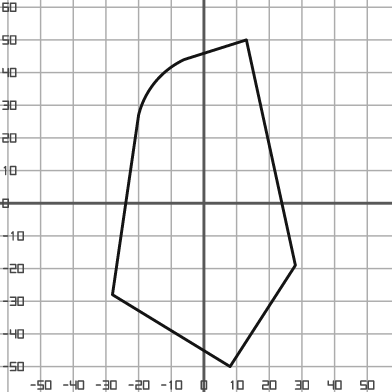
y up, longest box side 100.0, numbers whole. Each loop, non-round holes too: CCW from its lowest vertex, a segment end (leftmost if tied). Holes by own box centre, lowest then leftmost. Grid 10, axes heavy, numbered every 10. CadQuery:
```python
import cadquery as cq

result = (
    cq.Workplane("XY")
    .moveTo(8.0, -50.0)
    .lineTo(28.0, -19.0)
    .lineTo(13.0, 50.0)
    .lineTo(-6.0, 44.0)
    .threePointArc((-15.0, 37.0), (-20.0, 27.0))
    .lineTo(-28.0, -28.0)
    .close()
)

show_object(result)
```